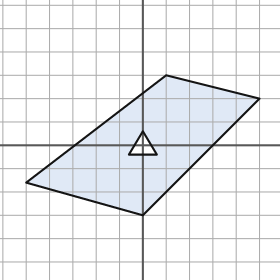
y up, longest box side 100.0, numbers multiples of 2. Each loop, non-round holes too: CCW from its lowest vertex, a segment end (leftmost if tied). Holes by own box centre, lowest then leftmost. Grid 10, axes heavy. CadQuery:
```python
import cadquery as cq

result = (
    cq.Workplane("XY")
    .moveTo(0.0, -30.0)
    .lineTo(50.0, 20.0)
    .lineTo(10.0, 30.0)
    .lineTo(-50.0, -16.0)
    .close()
    .moveTo(-6.0, -4.0)
    .lineTo(6.0, -4.0)
    .lineTo(0.0, 6.0)
    .close()
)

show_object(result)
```